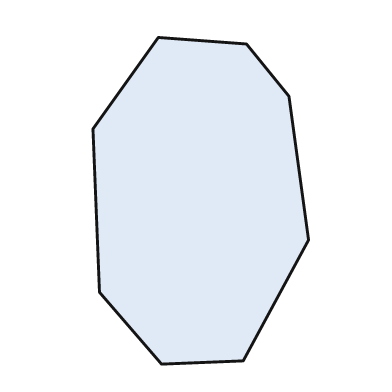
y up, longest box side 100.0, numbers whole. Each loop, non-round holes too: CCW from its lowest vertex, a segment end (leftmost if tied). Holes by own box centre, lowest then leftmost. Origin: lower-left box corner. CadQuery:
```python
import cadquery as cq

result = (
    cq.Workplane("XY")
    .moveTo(21.0, 0.0)
    .lineTo(46.0, 1.0)
    .lineTo(66.0, 38.0)
    .lineTo(60.0, 82.0)
    .lineTo(47.0, 98.0)
    .lineTo(20.0, 100.0)
    .lineTo(0.0, 72.0)
    .lineTo(2.0, 22.0)
    .close()
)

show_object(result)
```